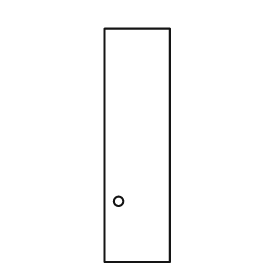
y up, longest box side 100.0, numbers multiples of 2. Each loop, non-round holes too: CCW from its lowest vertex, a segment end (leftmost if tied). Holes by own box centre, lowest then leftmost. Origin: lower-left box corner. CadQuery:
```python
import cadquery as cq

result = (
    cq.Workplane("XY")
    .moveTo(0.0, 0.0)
    .lineTo(28.0, 0.0)
    .lineTo(28.0, 100.0)
    .lineTo(0.0, 100.0)
    .close()
    .moveTo(6.0, 26.0)
    .circle(2.0)
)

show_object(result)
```